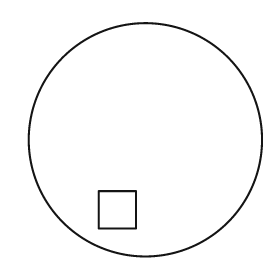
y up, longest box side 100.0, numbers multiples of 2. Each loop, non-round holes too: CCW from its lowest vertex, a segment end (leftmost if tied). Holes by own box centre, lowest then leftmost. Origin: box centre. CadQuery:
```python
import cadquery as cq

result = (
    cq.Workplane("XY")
    .moveTo(0.0, 0.0)
    .circle(50.0)
    .moveTo(-20.0, -38.0)
    .lineTo(-4.0, -38.0)
    .lineTo(-4.0, -22.0)
    .lineTo(-20.0, -22.0)
    .close()
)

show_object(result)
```